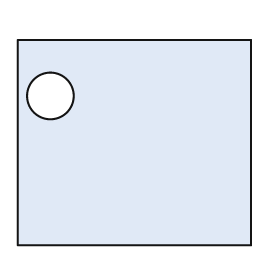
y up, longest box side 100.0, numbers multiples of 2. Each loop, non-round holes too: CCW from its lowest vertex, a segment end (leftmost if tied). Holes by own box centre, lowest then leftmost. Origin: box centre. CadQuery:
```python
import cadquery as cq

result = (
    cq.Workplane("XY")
    .moveTo(-50.0, -44.0)
    .lineTo(50.0, -44.0)
    .lineTo(50.0, 44.0)
    .lineTo(-50.0, 44.0)
    .close()
    .moveTo(-36.0, 20.0)
    .circle(10.0)
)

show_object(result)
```